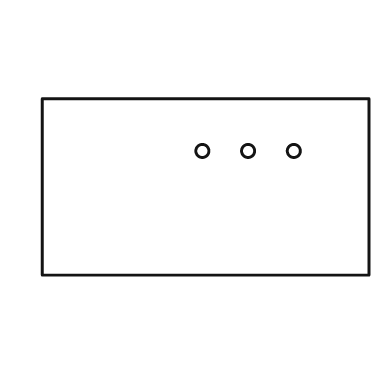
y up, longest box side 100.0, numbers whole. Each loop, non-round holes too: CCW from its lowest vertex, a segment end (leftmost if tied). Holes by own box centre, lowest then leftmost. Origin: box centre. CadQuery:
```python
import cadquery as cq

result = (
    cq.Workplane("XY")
    .moveTo(-50.0, -27.0)
    .lineTo(50.0, -27.0)
    .lineTo(50.0, 27.0)
    .lineTo(-50.0, 27.0)
    .close()
    .moveTo(-1.0, 11.0)
    .circle(2.0)
    .moveTo(13.0, 11.0)
    .circle(2.0)
    .moveTo(27.0, 11.0)
    .circle(2.0)
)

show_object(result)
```